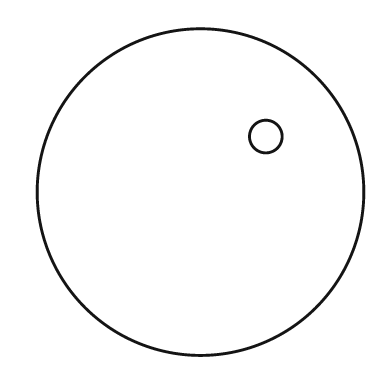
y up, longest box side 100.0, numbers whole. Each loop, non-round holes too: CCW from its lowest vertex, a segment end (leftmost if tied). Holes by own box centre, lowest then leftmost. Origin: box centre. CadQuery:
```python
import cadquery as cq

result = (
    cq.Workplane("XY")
    .moveTo(0.0, 0.0)
    .circle(50.0)
    .moveTo(20.0, 17.0)
    .circle(5.0)
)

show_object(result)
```